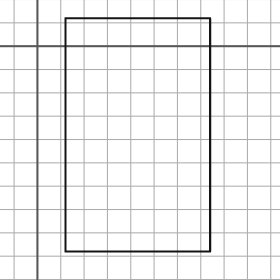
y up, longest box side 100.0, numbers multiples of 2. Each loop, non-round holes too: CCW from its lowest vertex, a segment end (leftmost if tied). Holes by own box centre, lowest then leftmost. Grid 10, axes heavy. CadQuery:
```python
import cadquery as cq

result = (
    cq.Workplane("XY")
    .moveTo(12.0, -88.0)
    .lineTo(74.0, -88.0)
    .lineTo(74.0, 12.0)
    .lineTo(12.0, 12.0)
    .close()
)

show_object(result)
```